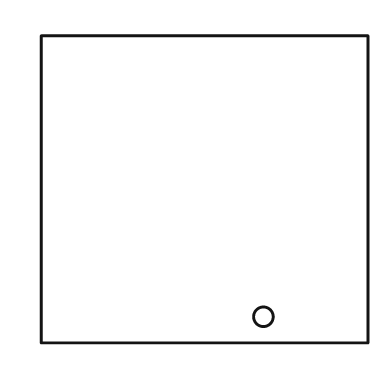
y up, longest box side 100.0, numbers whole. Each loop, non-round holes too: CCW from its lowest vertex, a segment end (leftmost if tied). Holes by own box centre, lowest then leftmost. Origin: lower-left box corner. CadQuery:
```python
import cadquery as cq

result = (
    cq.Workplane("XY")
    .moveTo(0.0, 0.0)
    .lineTo(100.0, 0.0)
    .lineTo(100.0, 94.0)
    .lineTo(0.0, 94.0)
    .close()
    .moveTo(68.0, 8.0)
    .circle(3.0)
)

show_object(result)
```